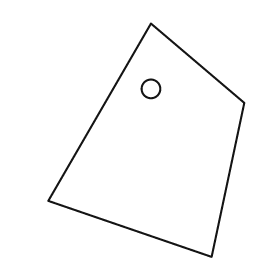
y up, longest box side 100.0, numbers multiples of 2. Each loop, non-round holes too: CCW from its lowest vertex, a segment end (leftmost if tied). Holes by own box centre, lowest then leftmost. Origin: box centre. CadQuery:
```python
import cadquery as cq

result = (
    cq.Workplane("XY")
    .moveTo(28.0, -50.0)
    .lineTo(42.0, 16.0)
    .lineTo(2.0, 50.0)
    .lineTo(-42.0, -26.0)
    .close()
    .moveTo(2.0, 22.0)
    .circle(4.0)
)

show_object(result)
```